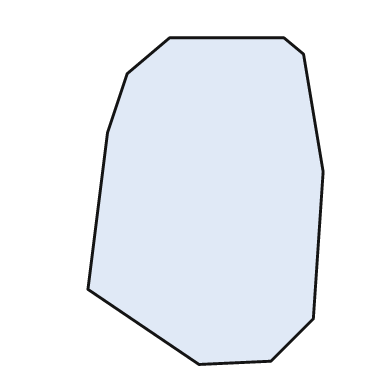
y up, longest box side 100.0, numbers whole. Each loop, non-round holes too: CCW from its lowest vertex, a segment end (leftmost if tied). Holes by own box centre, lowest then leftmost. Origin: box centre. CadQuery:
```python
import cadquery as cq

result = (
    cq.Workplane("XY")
    .moveTo(-2.0, -50.0)
    .lineTo(20.0, -49.0)
    .lineTo(33.0, -36.0)
    .lineTo(36.0, 9.0)
    .lineTo(30.0, 45.0)
    .lineTo(24.0, 50.0)
    .lineTo(-11.0, 50.0)
    .lineTo(-24.0, 39.0)
    .lineTo(-30.0, 21.0)
    .lineTo(-36.0, -27.0)
    .close()
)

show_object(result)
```